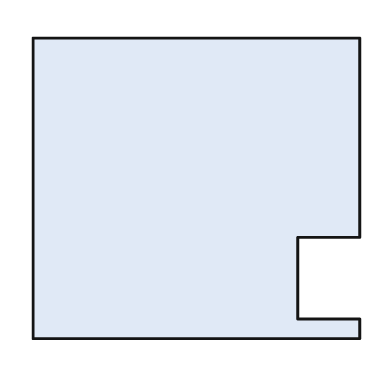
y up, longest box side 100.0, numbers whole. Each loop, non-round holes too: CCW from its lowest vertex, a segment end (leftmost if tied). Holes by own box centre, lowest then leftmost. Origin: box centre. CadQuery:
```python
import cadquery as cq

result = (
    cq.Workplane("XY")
    .moveTo(-50.0, -46.0)
    .lineTo(50.0, -46.0)
    .lineTo(50.0, -40.0)
    .lineTo(31.0, -40.0)
    .lineTo(31.0, -15.0)
    .lineTo(50.0, -15.0)
    .lineTo(50.0, 46.0)
    .lineTo(-50.0, 46.0)
    .close()
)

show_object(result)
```